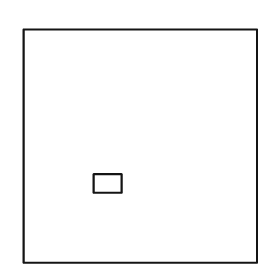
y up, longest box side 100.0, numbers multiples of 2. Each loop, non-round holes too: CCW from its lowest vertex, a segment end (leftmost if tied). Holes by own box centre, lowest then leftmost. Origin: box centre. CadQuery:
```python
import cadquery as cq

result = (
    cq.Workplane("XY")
    .moveTo(-50.0, -50.0)
    .lineTo(50.0, -50.0)
    .lineTo(50.0, 50.0)
    .lineTo(-50.0, 50.0)
    .close()
    .moveTo(-20.0, -20.0)
    .lineTo(-8.0, -20.0)
    .lineTo(-8.0, -12.0)
    .lineTo(-20.0, -12.0)
    .close()
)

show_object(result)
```